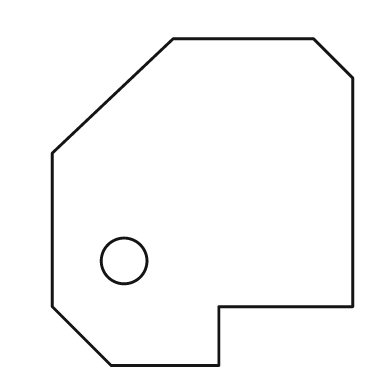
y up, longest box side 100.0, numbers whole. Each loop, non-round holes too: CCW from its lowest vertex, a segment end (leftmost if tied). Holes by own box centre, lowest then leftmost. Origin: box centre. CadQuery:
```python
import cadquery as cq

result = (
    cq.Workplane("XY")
    .moveTo(-28.0, -50.0)
    .lineTo(5.0, -50.0)
    .lineTo(5.0, -32.0)
    .lineTo(46.0, -32.0)
    .lineTo(46.0, 38.0)
    .lineTo(34.0, 50.0)
    .lineTo(-9.0, 50.0)
    .lineTo(-46.0, 15.0)
    .lineTo(-46.0, -32.0)
    .close()
    .moveTo(-24.0, -18.0)
    .circle(7.0)
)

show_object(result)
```